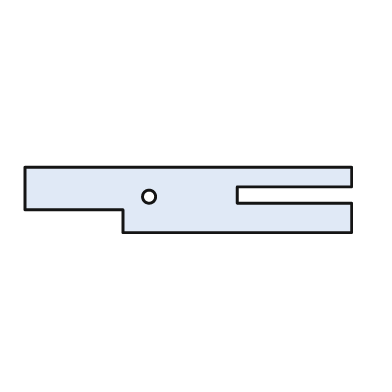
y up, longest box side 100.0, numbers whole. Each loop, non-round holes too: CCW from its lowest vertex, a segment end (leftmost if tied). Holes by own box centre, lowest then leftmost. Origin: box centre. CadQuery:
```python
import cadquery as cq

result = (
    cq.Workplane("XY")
    .moveTo(-20.0, -10.0)
    .lineTo(50.0, -10.0)
    .lineTo(50.0, -1.0)
    .lineTo(15.0, -1.0)
    .lineTo(15.0, 4.0)
    .lineTo(50.0, 4.0)
    .lineTo(50.0, 10.0)
    .lineTo(-50.0, 10.0)
    .lineTo(-50.0, -3.0)
    .lineTo(-20.0, -3.0)
    .close()
    .moveTo(-12.0, 1.0)
    .circle(2.0)
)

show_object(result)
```